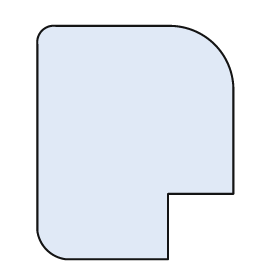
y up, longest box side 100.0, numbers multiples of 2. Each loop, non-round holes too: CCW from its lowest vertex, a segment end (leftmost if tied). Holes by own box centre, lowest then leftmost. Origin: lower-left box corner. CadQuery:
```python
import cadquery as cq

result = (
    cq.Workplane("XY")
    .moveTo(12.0, 0.0)
    .lineTo(56.0, 0.0)
    .lineTo(56.0, 28.0)
    .lineTo(84.0, 28.0)
    .lineTo(84.0, 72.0)
    .threePointArc((76.0, 92.0), (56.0, 100.0))
    .lineTo(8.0, 100.0)
    .threePointArc((2.0, 98.0), (0.0, 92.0))
    .lineTo(0.0, 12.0)
    .threePointArc((4.0, 4.0), (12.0, 0.0))
    .close()
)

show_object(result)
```